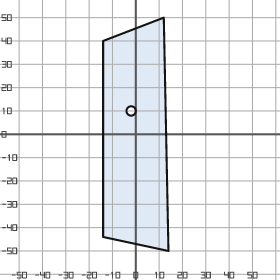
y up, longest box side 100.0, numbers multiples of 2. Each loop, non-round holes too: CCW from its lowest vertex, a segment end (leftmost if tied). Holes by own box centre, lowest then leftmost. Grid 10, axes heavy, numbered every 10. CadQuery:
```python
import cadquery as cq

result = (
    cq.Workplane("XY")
    .moveTo(14.0, -50.0)
    .lineTo(12.0, 50.0)
    .lineTo(-14.0, 40.0)
    .lineTo(-14.0, -44.0)
    .close()
    .moveTo(-2.0, 10.0)
    .circle(2.0)
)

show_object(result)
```